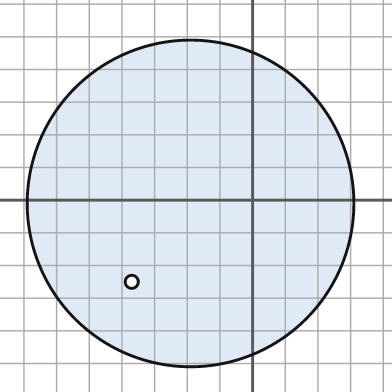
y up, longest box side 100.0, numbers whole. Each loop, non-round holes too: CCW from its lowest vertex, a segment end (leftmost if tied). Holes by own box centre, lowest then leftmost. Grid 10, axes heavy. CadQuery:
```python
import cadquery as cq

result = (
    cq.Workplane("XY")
    .moveTo(-19.0, -1.0)
    .circle(50.0)
    .moveTo(-37.0, -25.0)
    .circle(2.0)
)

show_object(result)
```